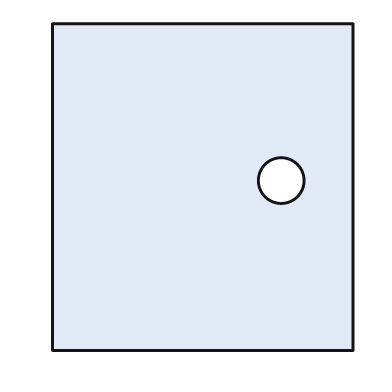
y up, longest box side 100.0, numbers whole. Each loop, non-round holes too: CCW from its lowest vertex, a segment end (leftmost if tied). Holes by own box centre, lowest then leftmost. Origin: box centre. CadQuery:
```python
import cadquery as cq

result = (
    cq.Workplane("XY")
    .moveTo(-46.0, -50.0)
    .lineTo(46.0, -50.0)
    .lineTo(46.0, 50.0)
    .lineTo(-46.0, 50.0)
    .close()
    .moveTo(24.0, 2.0)
    .circle(7.0)
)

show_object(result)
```